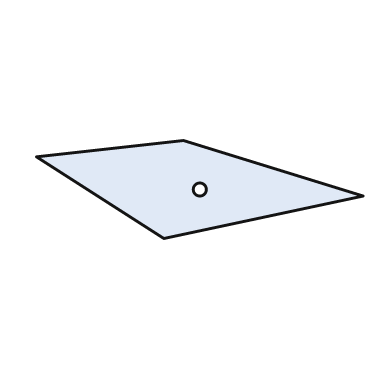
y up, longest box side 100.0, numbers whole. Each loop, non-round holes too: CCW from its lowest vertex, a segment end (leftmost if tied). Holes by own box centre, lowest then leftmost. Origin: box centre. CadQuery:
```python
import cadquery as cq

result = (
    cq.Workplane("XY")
    .moveTo(-11.0, -15.0)
    .lineTo(50.0, -2.0)
    .lineTo(-5.0, 15.0)
    .lineTo(-50.0, 10.0)
    .close()
    .moveTo(0.0, 0.0)
    .circle(2.0)
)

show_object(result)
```